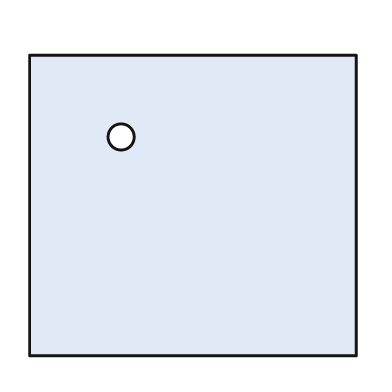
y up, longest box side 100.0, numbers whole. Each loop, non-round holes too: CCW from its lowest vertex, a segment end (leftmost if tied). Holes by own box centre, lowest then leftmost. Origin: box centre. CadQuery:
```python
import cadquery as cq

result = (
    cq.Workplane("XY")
    .moveTo(-50.0, -46.0)
    .lineTo(50.0, -46.0)
    .lineTo(50.0, 46.0)
    .lineTo(-50.0, 46.0)
    .close()
    .moveTo(-22.0, 21.0)
    .circle(4.0)
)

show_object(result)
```